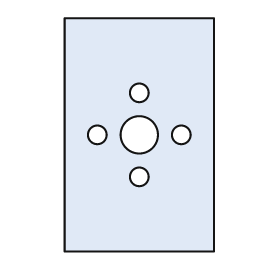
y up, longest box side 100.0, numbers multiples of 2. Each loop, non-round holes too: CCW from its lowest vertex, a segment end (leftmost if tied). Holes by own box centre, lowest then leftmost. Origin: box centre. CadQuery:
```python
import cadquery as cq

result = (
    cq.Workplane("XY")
    .moveTo(-32.0, -50.0)
    .lineTo(32.0, -50.0)
    .lineTo(32.0, 50.0)
    .lineTo(-32.0, 50.0)
    .close()
    .moveTo(0.0, -18.0)
    .circle(4.0)
    .moveTo(-18.0, 0.0)
    .circle(4.0)
    .moveTo(0.0, 0.0)
    .circle(8.0)
    .moveTo(18.0, 0.0)
    .circle(4.0)
    .moveTo(0.0, 18.0)
    .circle(4.0)
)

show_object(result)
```